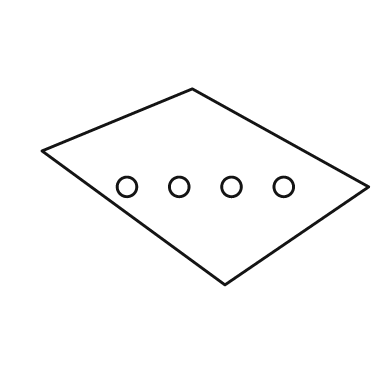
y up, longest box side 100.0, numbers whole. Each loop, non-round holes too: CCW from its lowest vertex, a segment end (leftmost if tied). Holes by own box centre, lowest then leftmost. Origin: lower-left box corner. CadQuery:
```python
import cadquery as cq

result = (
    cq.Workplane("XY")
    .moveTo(56.0, 0.0)
    .lineTo(100.0, 30.0)
    .lineTo(46.0, 60.0)
    .lineTo(0.0, 41.0)
    .close()
    .moveTo(26.0, 30.0)
    .circle(3.0)
    .moveTo(42.0, 30.0)
    .circle(3.0)
    .moveTo(58.0, 30.0)
    .circle(3.0)
    .moveTo(74.0, 30.0)
    .circle(3.0)
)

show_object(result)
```